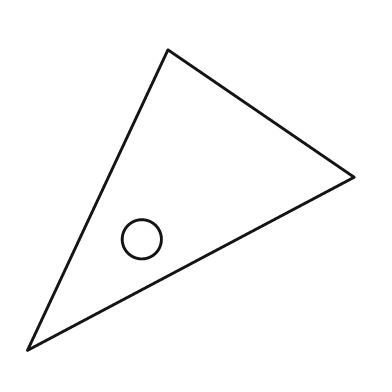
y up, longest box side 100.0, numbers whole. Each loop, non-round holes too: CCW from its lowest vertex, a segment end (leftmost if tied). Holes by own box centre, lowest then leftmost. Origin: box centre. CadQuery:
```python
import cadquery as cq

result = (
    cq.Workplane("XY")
    .moveTo(-50.0, -46.0)
    .lineTo(50.0, 7.0)
    .lineTo(-7.0, 46.0)
    .close()
    .moveTo(-15.0, -12.0)
    .circle(6.0)
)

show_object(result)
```